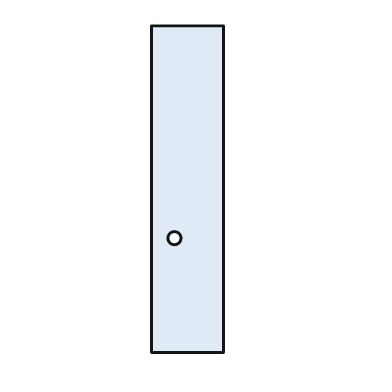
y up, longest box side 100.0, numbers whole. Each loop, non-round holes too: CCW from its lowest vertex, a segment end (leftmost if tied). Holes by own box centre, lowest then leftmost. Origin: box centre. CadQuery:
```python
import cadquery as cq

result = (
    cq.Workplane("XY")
    .moveTo(-11.0, -50.0)
    .lineTo(11.0, -50.0)
    .lineTo(11.0, 50.0)
    .lineTo(-11.0, 50.0)
    .close()
    .moveTo(-4.0, -15.0)
    .circle(2.0)
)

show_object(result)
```